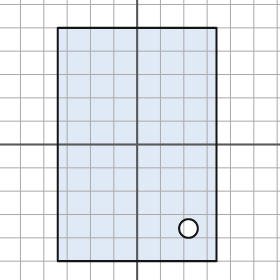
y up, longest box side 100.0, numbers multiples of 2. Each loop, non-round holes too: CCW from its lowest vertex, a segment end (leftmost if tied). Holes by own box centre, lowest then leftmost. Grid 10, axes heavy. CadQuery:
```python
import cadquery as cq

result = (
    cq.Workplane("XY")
    .moveTo(-34.0, -50.0)
    .lineTo(34.0, -50.0)
    .lineTo(34.0, 50.0)
    .lineTo(-34.0, 50.0)
    .close()
    .moveTo(22.0, -36.0)
    .circle(4.0)
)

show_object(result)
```